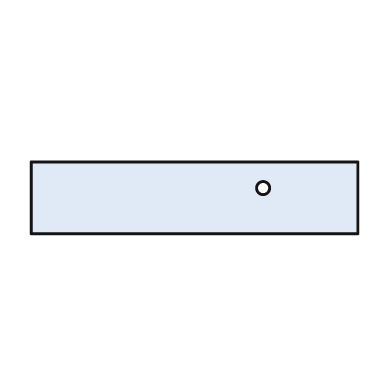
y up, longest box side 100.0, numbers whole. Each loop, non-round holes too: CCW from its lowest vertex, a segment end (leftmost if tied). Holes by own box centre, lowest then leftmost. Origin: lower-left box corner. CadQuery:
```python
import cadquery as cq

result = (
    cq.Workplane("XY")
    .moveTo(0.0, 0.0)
    .lineTo(100.0, 0.0)
    .lineTo(100.0, 22.0)
    .lineTo(0.0, 22.0)
    .close()
    .moveTo(71.0, 14.0)
    .circle(2.0)
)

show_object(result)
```